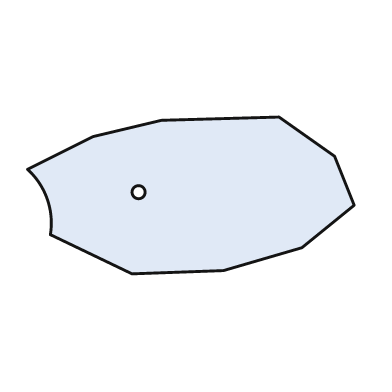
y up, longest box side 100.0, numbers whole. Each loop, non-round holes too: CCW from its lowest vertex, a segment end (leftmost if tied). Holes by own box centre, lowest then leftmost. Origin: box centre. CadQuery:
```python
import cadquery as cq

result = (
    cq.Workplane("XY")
    .moveTo(-18.0, -24.0)
    .lineTo(10.0, -23.0)
    .lineTo(34.0, -16.0)
    .lineTo(50.0, -3.0)
    .lineTo(44.0, 12.0)
    .lineTo(27.0, 24.0)
    .lineTo(-9.0, 23.0)
    .lineTo(-30.0, 18.0)
    .lineTo(-50.0, 8.0)
    .threePointArc((-44.0, -1.0), (-43.0, -12.0))
    .close()
    .moveTo(-16.0, 1.0)
    .circle(2.0)
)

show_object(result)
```